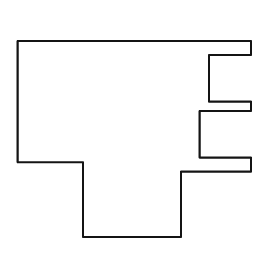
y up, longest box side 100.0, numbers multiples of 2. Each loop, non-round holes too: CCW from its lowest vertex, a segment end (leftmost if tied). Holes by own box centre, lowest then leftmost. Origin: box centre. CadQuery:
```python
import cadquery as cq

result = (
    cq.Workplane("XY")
    .moveTo(-22.0, -42.0)
    .lineTo(20.0, -42.0)
    .lineTo(20.0, -14.0)
    .lineTo(50.0, -14.0)
    .lineTo(50.0, -8.0)
    .lineTo(28.0, -8.0)
    .lineTo(28.0, 12.0)
    .lineTo(50.0, 12.0)
    .lineTo(50.0, 16.0)
    .lineTo(32.0, 16.0)
    .lineTo(32.0, 36.0)
    .lineTo(50.0, 36.0)
    .lineTo(50.0, 42.0)
    .lineTo(-50.0, 42.0)
    .lineTo(-50.0, -10.0)
    .lineTo(-22.0, -10.0)
    .close()
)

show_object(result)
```